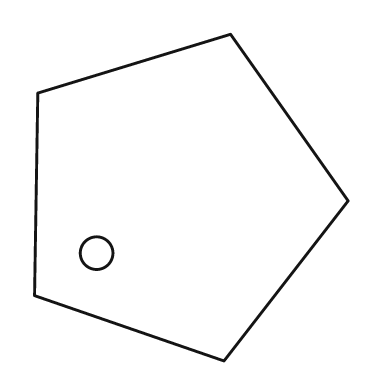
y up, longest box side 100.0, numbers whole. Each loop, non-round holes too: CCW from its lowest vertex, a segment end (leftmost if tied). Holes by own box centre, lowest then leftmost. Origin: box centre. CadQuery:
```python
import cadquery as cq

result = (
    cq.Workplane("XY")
    .moveTo(10.0, -50.0)
    .lineTo(48.0, -1.0)
    .lineTo(12.0, 50.0)
    .lineTo(-47.0, 32.0)
    .lineTo(-48.0, -30.0)
    .close()
    .moveTo(-29.0, -17.0)
    .circle(5.0)
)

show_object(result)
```